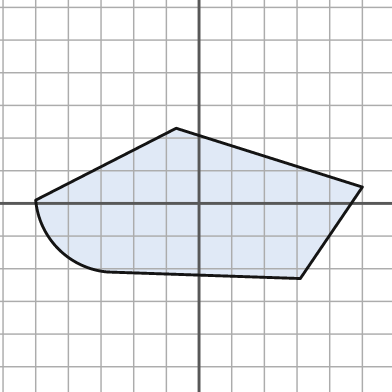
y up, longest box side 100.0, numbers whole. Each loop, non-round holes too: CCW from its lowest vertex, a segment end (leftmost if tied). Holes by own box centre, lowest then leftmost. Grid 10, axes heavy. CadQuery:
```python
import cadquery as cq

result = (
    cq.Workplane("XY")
    .moveTo(31.0, -23.0)
    .lineTo(50.0, 5.0)
    .lineTo(-7.0, 23.0)
    .lineTo(-50.0, 1.0)
    .threePointArc((-43.0, -14.0), (-28.0, -21.0))
    .close()
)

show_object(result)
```